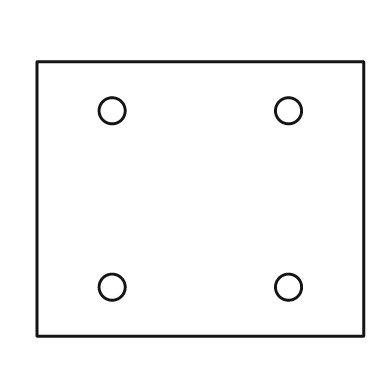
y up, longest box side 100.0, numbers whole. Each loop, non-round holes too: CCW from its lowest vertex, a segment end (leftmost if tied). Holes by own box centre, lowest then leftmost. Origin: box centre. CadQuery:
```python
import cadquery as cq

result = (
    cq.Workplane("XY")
    .moveTo(-50.0, -42.0)
    .lineTo(50.0, -42.0)
    .lineTo(50.0, 42.0)
    .lineTo(-50.0, 42.0)
    .close()
    .moveTo(-27.0, -27.0)
    .circle(4.0)
    .moveTo(27.0, -27.0)
    .circle(4.0)
    .moveTo(-27.0, 27.0)
    .circle(4.0)
    .moveTo(27.0, 27.0)
    .circle(4.0)
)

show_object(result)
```